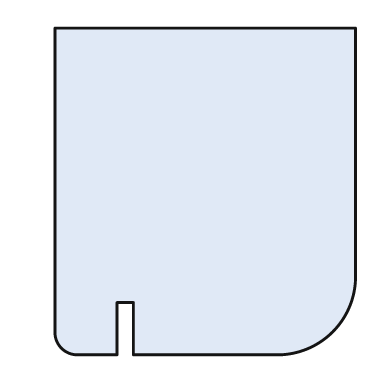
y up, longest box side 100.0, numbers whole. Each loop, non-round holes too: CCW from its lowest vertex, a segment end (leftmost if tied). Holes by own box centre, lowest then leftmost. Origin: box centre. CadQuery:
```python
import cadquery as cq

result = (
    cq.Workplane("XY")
    .moveTo(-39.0, -50.0)
    .lineTo(-27.0, -50.0)
    .lineTo(-27.0, -34.0)
    .lineTo(-22.0, -34.0)
    .lineTo(-22.0, -50.0)
    .lineTo(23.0, -50.0)
    .threePointArc((39.0, -43.0), (46.0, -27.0))
    .lineTo(46.0, 50.0)
    .lineTo(-46.0, 50.0)
    .lineTo(-46.0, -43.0)
    .threePointArc((-44.0, -48.0), (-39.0, -50.0))
    .close()
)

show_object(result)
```